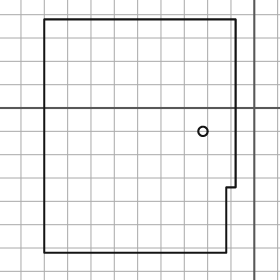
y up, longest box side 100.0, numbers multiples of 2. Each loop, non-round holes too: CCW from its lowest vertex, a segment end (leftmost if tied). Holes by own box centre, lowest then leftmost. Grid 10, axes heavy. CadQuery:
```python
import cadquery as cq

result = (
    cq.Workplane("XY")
    .moveTo(-90.0, -62.0)
    .lineTo(-12.0, -62.0)
    .lineTo(-12.0, -34.0)
    .lineTo(-8.0, -34.0)
    .lineTo(-8.0, 38.0)
    .lineTo(-90.0, 38.0)
    .close()
    .moveTo(-22.0, -10.0)
    .circle(2.0)
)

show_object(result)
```